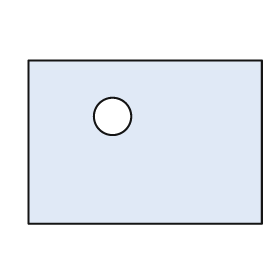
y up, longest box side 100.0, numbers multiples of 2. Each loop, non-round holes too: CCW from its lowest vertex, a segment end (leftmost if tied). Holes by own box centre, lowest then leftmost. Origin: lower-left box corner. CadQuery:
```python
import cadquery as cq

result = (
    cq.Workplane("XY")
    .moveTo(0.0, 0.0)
    .lineTo(100.0, 0.0)
    .lineTo(100.0, 70.0)
    .lineTo(0.0, 70.0)
    .close()
    .moveTo(36.0, 46.0)
    .circle(8.0)
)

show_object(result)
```